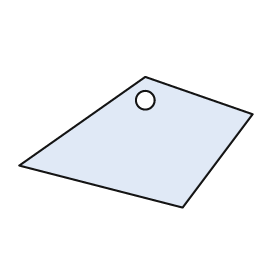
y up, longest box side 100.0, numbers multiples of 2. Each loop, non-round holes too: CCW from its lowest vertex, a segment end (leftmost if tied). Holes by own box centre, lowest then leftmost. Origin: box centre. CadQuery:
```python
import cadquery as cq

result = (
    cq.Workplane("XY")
    .moveTo(20.0, -28.0)
    .lineTo(50.0, 12.0)
    .lineTo(4.0, 28.0)
    .lineTo(-50.0, -10.0)
    .close()
    .moveTo(4.0, 18.0)
    .circle(4.0)
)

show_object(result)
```